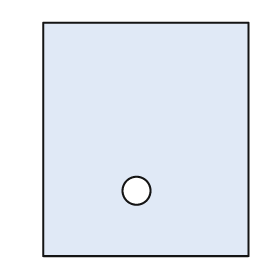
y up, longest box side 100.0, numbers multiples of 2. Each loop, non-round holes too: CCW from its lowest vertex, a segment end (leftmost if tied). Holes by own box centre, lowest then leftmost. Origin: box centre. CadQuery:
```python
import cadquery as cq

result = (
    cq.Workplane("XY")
    .moveTo(-44.0, -50.0)
    .lineTo(44.0, -50.0)
    .lineTo(44.0, 50.0)
    .lineTo(-44.0, 50.0)
    .close()
    .moveTo(-4.0, -22.0)
    .circle(6.0)
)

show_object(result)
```